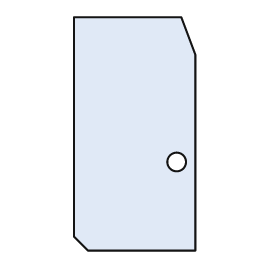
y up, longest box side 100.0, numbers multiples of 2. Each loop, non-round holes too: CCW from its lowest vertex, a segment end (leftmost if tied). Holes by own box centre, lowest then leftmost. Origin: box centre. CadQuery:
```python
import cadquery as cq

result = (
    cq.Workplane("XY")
    .moveTo(-20.0, -50.0)
    .lineTo(26.0, -50.0)
    .lineTo(26.0, 34.0)
    .lineTo(20.0, 50.0)
    .lineTo(-26.0, 50.0)
    .lineTo(-26.0, -44.0)
    .close()
    .moveTo(18.0, -12.0)
    .circle(4.0)
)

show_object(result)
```